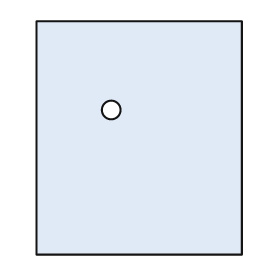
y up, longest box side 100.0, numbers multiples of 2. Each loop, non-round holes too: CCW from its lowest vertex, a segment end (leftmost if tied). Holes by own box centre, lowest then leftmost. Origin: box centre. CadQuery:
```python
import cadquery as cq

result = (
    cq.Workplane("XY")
    .moveTo(-44.0, -50.0)
    .lineTo(44.0, -50.0)
    .lineTo(44.0, 50.0)
    .lineTo(-44.0, 50.0)
    .close()
    .moveTo(-12.0, 12.0)
    .circle(4.0)
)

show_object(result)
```